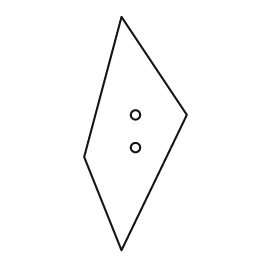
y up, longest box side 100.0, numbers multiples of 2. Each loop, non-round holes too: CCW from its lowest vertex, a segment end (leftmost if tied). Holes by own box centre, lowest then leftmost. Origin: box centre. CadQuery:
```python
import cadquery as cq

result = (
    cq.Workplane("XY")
    .moveTo(-6.0, -50.0)
    .lineTo(22.0, 8.0)
    .lineTo(-6.0, 50.0)
    .lineTo(-22.0, -10.0)
    .close()
    .moveTo(0.0, -6.0)
    .circle(2.0)
    .moveTo(0.0, 8.0)
    .circle(2.0)
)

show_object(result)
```